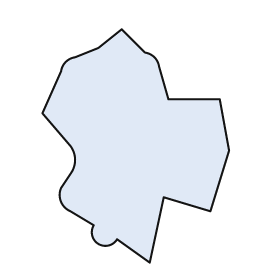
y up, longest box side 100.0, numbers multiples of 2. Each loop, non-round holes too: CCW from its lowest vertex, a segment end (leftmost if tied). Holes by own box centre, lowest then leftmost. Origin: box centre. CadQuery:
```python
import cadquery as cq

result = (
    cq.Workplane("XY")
    .moveTo(6.0, -50.0)
    .lineTo(12.0, -22.0)
    .lineTo(32.0, -28.0)
    .lineTo(40.0, -2.0)
    .lineTo(36.0, 20.0)
    .lineTo(14.0, 20.0)
    .lineTo(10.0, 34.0)
    .threePointArc((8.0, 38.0), (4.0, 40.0))
    .lineTo(-6.0, 50.0)
    .lineTo(-16.0, 42.0)
    .lineTo(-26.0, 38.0)
    .threePointArc((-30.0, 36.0), (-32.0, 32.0))
    .lineTo(-40.0, 14.0)
    .lineTo(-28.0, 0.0)
    .threePointArc((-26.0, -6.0), (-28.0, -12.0))
    .lineTo(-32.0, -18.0)
    .threePointArc((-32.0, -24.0), (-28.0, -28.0))
    .lineTo(-18.0, -34.0)
    .threePointArc((-16.0, -42.0), (-8.0, -40.0))
    .close()
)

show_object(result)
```